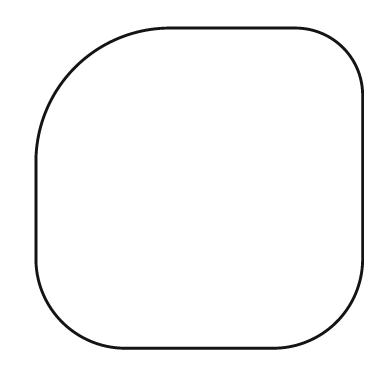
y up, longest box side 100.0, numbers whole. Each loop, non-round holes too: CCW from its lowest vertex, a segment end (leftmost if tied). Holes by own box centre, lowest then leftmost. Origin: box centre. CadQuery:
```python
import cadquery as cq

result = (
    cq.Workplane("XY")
    .moveTo(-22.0, -49.0)
    .lineTo(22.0, -49.0)
    .threePointArc((42.0, -41.0), (50.0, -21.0))
    .lineTo(50.0, 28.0)
    .threePointArc((44.0, 43.0), (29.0, 49.0))
    .lineTo(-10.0, 49.0)
    .threePointArc((-38.0, 37.0), (-50.0, 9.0))
    .lineTo(-50.0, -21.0)
    .threePointArc((-42.0, -41.0), (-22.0, -49.0))
    .close()
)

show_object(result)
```